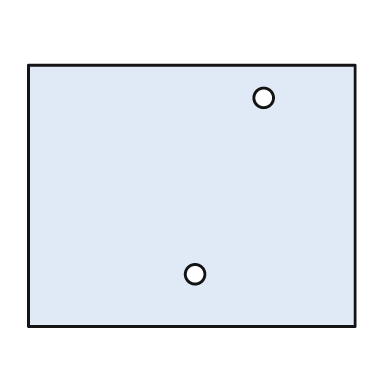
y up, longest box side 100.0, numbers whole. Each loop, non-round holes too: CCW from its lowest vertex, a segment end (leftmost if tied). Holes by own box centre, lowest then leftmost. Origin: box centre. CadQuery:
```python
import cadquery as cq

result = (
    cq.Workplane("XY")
    .moveTo(-50.0, -40.0)
    .lineTo(50.0, -40.0)
    .lineTo(50.0, 40.0)
    .lineTo(-50.0, 40.0)
    .close()
    .moveTo(1.0, -24.0)
    .circle(3.0)
    .moveTo(22.0, 30.0)
    .circle(3.0)
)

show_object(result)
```